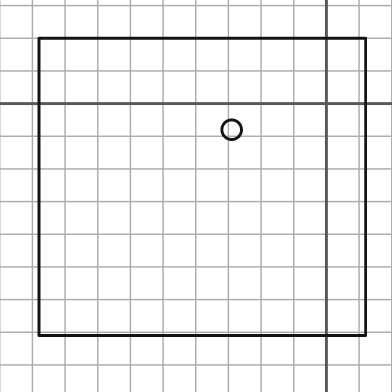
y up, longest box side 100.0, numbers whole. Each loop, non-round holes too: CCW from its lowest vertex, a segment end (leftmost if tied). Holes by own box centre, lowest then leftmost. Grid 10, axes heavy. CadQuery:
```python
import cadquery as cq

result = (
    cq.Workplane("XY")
    .moveTo(-88.0, -71.0)
    .lineTo(12.0, -71.0)
    .lineTo(12.0, 20.0)
    .lineTo(-88.0, 20.0)
    .close()
    .moveTo(-29.0, -8.0)
    .circle(3.0)
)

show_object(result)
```